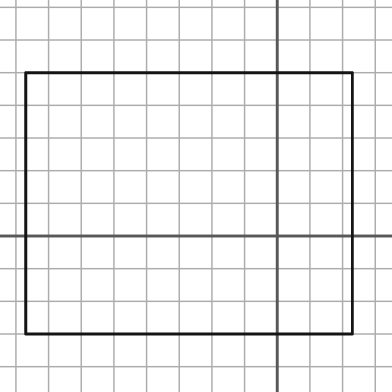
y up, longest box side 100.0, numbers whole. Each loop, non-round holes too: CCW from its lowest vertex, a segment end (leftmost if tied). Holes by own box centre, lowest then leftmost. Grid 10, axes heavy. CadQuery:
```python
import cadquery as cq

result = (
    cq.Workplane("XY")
    .moveTo(-77.0, -30.0)
    .lineTo(23.0, -30.0)
    .lineTo(23.0, 50.0)
    .lineTo(-77.0, 50.0)
    .close()
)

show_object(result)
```